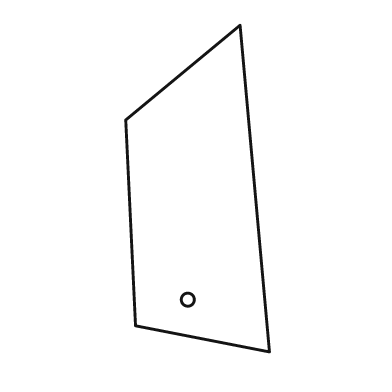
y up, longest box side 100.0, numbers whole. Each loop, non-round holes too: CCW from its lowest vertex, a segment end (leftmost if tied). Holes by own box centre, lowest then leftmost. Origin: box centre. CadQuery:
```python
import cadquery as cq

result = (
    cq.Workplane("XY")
    .moveTo(22.0, -50.0)
    .lineTo(13.0, 50.0)
    .lineTo(-22.0, 21.0)
    .lineTo(-19.0, -42.0)
    .close()
    .moveTo(-3.0, -34.0)
    .circle(2.0)
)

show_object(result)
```